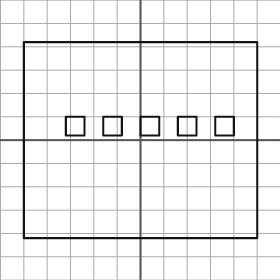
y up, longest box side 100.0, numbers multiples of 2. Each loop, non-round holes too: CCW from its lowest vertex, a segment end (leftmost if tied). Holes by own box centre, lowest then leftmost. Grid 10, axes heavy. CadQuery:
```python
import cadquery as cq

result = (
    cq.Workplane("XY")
    .moveTo(-50.0, -42.0)
    .lineTo(50.0, -42.0)
    .lineTo(50.0, 42.0)
    .lineTo(-50.0, 42.0)
    .close()
    .moveTo(-32.0, 2.0)
    .lineTo(-24.0, 2.0)
    .lineTo(-24.0, 10.0)
    .lineTo(-32.0, 10.0)
    .close()
    .moveTo(-16.0, 2.0)
    .lineTo(-8.0, 2.0)
    .lineTo(-8.0, 10.0)
    .lineTo(-16.0, 10.0)
    .close()
    .moveTo(0.0, 2.0)
    .lineTo(8.0, 2.0)
    .lineTo(8.0, 10.0)
    .lineTo(0.0, 10.0)
    .close()
    .moveTo(16.0, 2.0)
    .lineTo(24.0, 2.0)
    .lineTo(24.0, 10.0)
    .lineTo(16.0, 10.0)
    .close()
    .moveTo(32.0, 2.0)
    .lineTo(40.0, 2.0)
    .lineTo(40.0, 10.0)
    .lineTo(32.0, 10.0)
    .close()
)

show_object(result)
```